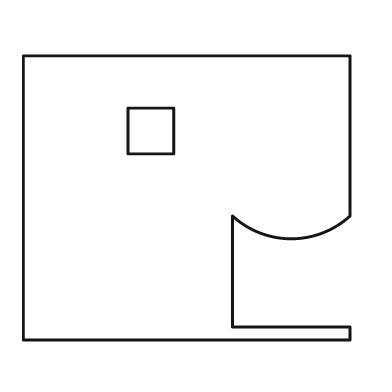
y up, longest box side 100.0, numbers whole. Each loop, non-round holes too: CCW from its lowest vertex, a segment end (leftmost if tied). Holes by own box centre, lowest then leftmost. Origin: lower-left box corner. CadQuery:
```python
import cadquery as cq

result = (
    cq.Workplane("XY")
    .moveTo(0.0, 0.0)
    .lineTo(100.0, 0.0)
    .lineTo(100.0, 4.0)
    .lineTo(64.0, 4.0)
    .lineTo(64.0, 38.0)
    .threePointArc((82.0, 31.0), (100.0, 38.0))
    .lineTo(100.0, 87.0)
    .lineTo(0.0, 87.0)
    .close()
    .moveTo(32.0, 57.0)
    .lineTo(46.0, 57.0)
    .lineTo(46.0, 71.0)
    .lineTo(32.0, 71.0)
    .close()
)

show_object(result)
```